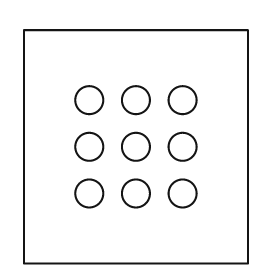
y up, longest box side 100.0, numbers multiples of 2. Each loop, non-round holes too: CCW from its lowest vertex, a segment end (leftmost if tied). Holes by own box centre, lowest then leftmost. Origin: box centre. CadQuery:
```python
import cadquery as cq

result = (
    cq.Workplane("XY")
    .moveTo(-48.0, -50.0)
    .lineTo(48.0, -50.0)
    .lineTo(48.0, 50.0)
    .lineTo(-48.0, 50.0)
    .close()
    .moveTo(-20.0, -20.0)
    .circle(6.0)
    .moveTo(0.0, -20.0)
    .circle(6.0)
    .moveTo(20.0, -20.0)
    .circle(6.0)
    .moveTo(-20.0, 0.0)
    .circle(6.0)
    .moveTo(0.0, 0.0)
    .circle(6.0)
    .moveTo(20.0, 0.0)
    .circle(6.0)
    .moveTo(-20.0, 20.0)
    .circle(6.0)
    .moveTo(0.0, 20.0)
    .circle(6.0)
    .moveTo(20.0, 20.0)
    .circle(6.0)
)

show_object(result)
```